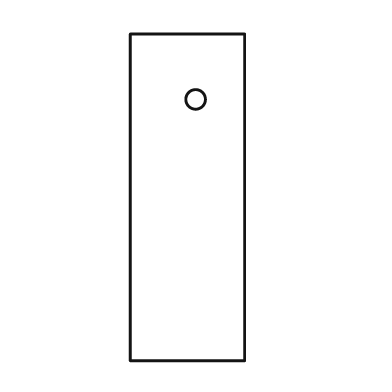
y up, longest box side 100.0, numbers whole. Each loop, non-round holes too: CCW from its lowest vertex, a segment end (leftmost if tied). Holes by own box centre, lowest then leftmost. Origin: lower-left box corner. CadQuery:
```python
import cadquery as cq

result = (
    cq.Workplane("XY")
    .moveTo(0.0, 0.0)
    .lineTo(35.0, 0.0)
    .lineTo(35.0, 100.0)
    .lineTo(0.0, 100.0)
    .close()
    .moveTo(20.0, 80.0)
    .circle(3.0)
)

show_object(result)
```